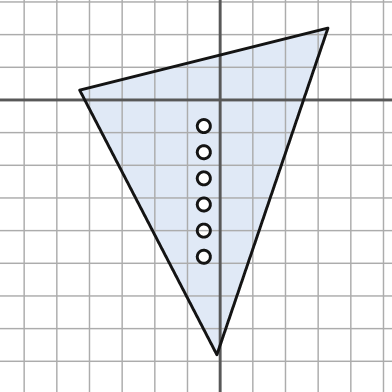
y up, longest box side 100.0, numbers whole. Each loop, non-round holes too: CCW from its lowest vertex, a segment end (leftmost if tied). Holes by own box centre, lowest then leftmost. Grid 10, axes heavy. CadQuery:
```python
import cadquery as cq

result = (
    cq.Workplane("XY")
    .moveTo(-1.0, -78.0)
    .lineTo(33.0, 22.0)
    .lineTo(-43.0, 3.0)
    .close()
    .moveTo(-5.0, -48.0)
    .circle(2.0)
    .moveTo(-5.0, -40.0)
    .circle(2.0)
    .moveTo(-5.0, -32.0)
    .circle(2.0)
    .moveTo(-5.0, -24.0)
    .circle(2.0)
    .moveTo(-5.0, -16.0)
    .circle(2.0)
    .moveTo(-5.0, -8.0)
    .circle(2.0)
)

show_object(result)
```